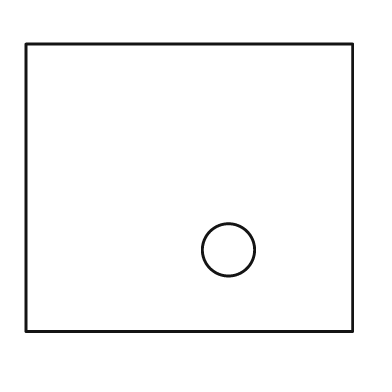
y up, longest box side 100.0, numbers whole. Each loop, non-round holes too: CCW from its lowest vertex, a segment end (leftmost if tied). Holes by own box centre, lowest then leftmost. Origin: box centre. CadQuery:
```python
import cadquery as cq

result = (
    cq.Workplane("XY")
    .moveTo(-50.0, -44.0)
    .lineTo(50.0, -44.0)
    .lineTo(50.0, 44.0)
    .lineTo(-50.0, 44.0)
    .close()
    .moveTo(12.0, -19.0)
    .circle(8.0)
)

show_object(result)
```